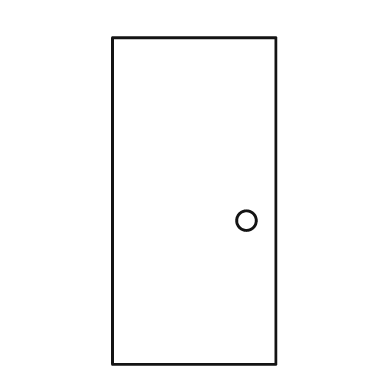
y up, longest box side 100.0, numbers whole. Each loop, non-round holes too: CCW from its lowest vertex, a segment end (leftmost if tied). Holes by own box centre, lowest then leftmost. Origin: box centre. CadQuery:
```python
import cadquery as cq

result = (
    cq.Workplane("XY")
    .moveTo(-25.0, -50.0)
    .lineTo(25.0, -50.0)
    .lineTo(25.0, 50.0)
    .lineTo(-25.0, 50.0)
    .close()
    .moveTo(16.0, -6.0)
    .circle(3.0)
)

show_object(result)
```